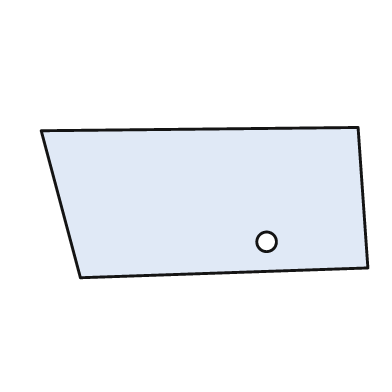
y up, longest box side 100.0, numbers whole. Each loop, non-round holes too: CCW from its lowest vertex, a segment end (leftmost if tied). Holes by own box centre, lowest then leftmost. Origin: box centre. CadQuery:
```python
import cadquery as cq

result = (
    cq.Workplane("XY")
    .moveTo(-38.0, -23.0)
    .lineTo(50.0, -20.0)
    .lineTo(47.0, 23.0)
    .lineTo(-50.0, 22.0)
    .close()
    .moveTo(19.0, -12.0)
    .circle(3.0)
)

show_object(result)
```